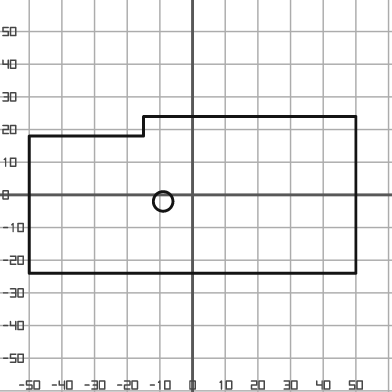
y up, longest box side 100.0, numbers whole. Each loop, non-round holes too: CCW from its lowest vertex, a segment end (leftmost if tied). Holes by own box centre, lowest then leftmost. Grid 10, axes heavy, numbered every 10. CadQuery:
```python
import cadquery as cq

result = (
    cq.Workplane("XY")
    .moveTo(-50.0, -24.0)
    .lineTo(50.0, -24.0)
    .lineTo(50.0, 24.0)
    .lineTo(-15.0, 24.0)
    .lineTo(-15.0, 18.0)
    .lineTo(-50.0, 18.0)
    .close()
    .moveTo(-9.0, -2.0)
    .circle(3.0)
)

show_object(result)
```